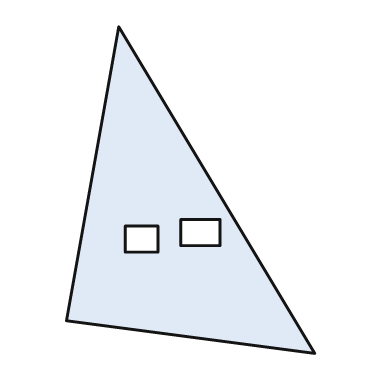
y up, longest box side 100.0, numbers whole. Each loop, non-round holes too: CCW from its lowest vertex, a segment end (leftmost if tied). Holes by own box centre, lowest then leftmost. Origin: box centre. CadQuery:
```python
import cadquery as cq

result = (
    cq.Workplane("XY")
    .moveTo(38.0, -50.0)
    .lineTo(-22.0, 50.0)
    .lineTo(-38.0, -40.0)
    .close()
    .moveTo(-20.0, -19.0)
    .lineTo(-10.0, -19.0)
    .lineTo(-10.0, -11.0)
    .lineTo(-20.0, -11.0)
    .close()
    .moveTo(-3.0, -17.0)
    .lineTo(9.0, -17.0)
    .lineTo(9.0, -9.0)
    .lineTo(-3.0, -9.0)
    .close()
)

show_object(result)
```